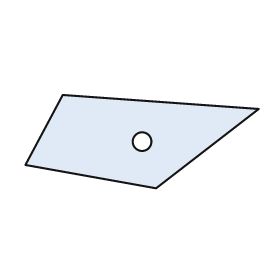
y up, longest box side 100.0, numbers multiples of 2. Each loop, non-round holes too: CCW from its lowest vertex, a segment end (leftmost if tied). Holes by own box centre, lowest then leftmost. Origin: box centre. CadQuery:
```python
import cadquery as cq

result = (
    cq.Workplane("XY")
    .moveTo(6.0, -20.0)
    .lineTo(50.0, 14.0)
    .lineTo(-34.0, 20.0)
    .lineTo(-50.0, -10.0)
    .close()
    .moveTo(0.0, 0.0)
    .circle(4.0)
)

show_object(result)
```